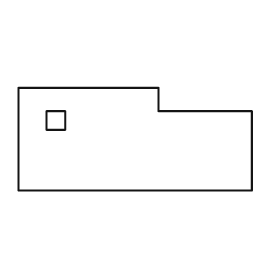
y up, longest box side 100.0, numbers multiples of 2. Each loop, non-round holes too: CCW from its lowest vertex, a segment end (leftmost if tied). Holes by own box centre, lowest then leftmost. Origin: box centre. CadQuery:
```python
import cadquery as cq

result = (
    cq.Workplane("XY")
    .moveTo(-50.0, -22.0)
    .lineTo(50.0, -22.0)
    .lineTo(50.0, 12.0)
    .lineTo(10.0, 12.0)
    .lineTo(10.0, 22.0)
    .lineTo(-50.0, 22.0)
    .close()
    .moveTo(-38.0, 4.0)
    .lineTo(-30.0, 4.0)
    .lineTo(-30.0, 12.0)
    .lineTo(-38.0, 12.0)
    .close()
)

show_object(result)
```